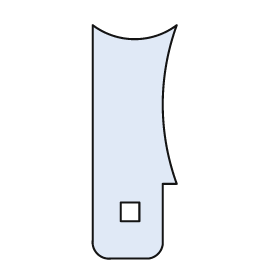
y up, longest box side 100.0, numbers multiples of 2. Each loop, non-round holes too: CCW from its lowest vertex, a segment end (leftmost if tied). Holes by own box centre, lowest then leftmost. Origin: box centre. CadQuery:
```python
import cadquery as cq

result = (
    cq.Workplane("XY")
    .moveTo(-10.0, -50.0)
    .lineTo(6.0, -50.0)
    .threePointArc((10.0, -48.0), (12.0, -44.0))
    .lineTo(12.0, -18.0)
    .lineTo(18.0, -18.0)
    .threePointArc((12.0, 16.0), (18.0, 50.0))
    .threePointArc((0.0, 44.0), (-18.0, 50.0))
    .lineTo(-18.0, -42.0)
    .threePointArc((-16.0, -48.0), (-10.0, -50.0))
    .close()
    .moveTo(-6.0, -34.0)
    .lineTo(2.0, -34.0)
    .lineTo(2.0, -26.0)
    .lineTo(-6.0, -26.0)
    .close()
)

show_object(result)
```